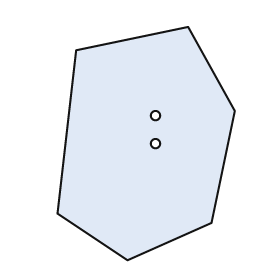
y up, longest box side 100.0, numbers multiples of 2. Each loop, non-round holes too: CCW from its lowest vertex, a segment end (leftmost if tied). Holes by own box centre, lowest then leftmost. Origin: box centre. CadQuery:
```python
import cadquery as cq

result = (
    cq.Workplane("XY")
    .moveTo(-8.0, -50.0)
    .lineTo(28.0, -34.0)
    .lineTo(38.0, 14.0)
    .lineTo(18.0, 50.0)
    .lineTo(-30.0, 40.0)
    .lineTo(-38.0, -30.0)
    .close()
    .moveTo(4.0, 0.0)
    .circle(2.0)
    .moveTo(4.0, 12.0)
    .circle(2.0)
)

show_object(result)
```